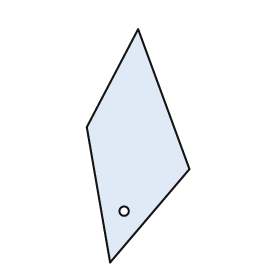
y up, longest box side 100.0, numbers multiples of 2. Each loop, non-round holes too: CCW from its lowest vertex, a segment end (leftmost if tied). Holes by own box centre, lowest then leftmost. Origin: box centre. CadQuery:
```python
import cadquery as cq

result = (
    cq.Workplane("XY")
    .moveTo(-12.0, -50.0)
    .lineTo(22.0, -10.0)
    .lineTo(0.0, 50.0)
    .lineTo(-22.0, 8.0)
    .close()
    .moveTo(-6.0, -28.0)
    .circle(2.0)
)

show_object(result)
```